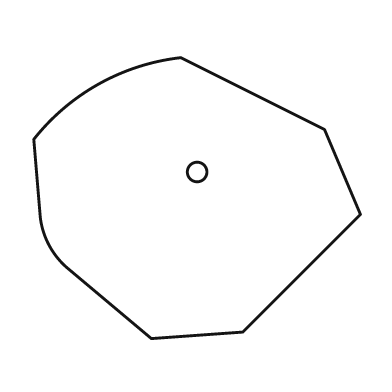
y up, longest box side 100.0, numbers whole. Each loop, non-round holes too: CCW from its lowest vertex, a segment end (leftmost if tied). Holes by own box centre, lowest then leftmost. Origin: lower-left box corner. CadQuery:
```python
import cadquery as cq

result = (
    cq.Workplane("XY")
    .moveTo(36.0, 0.0)
    .lineTo(64.0, 2.0)
    .lineTo(100.0, 38.0)
    .lineTo(89.0, 64.0)
    .lineTo(45.0, 86.0)
    .threePointArc((20.0, 78.0), (0.0, 61.0))
    .lineTo(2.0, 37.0)
    .threePointArc((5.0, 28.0), (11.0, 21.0))
    .close()
    .moveTo(50.0, 51.0)
    .circle(3.0)
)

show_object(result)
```